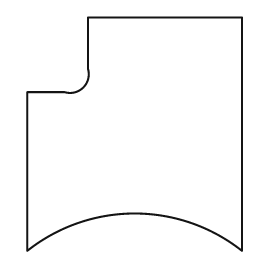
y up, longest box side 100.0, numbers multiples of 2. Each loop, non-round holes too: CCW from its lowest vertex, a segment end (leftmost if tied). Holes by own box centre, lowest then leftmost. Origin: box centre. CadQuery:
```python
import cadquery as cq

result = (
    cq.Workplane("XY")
    .moveTo(-46.0, -50.0)
    .threePointArc((0.0, -34.0), (46.0, -50.0))
    .lineTo(46.0, 50.0)
    .lineTo(-20.0, 50.0)
    .lineTo(-20.0, 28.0)
    .threePointArc((-22.0, 20.0), (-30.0, 18.0))
    .lineTo(-46.0, 18.0)
    .close()
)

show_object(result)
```